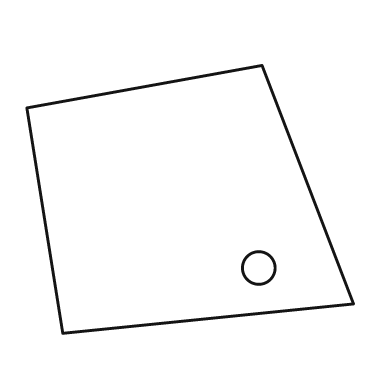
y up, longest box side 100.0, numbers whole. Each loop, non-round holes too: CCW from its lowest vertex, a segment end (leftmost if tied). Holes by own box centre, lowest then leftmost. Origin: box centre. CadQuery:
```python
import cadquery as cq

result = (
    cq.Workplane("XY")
    .moveTo(-39.0, -41.0)
    .lineTo(50.0, -32.0)
    .lineTo(22.0, 41.0)
    .lineTo(-50.0, 28.0)
    .close()
    .moveTo(21.0, -21.0)
    .circle(5.0)
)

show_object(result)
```